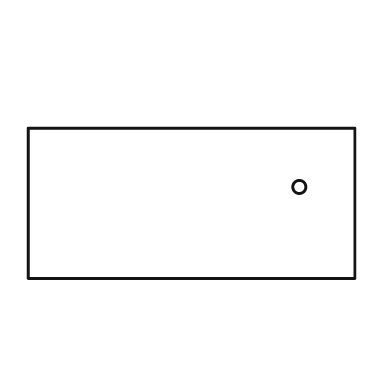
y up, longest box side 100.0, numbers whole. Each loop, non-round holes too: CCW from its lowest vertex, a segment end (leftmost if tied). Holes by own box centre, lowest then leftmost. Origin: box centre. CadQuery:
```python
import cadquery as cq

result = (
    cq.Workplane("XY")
    .moveTo(-50.0, -23.0)
    .lineTo(50.0, -23.0)
    .lineTo(50.0, 23.0)
    .lineTo(-50.0, 23.0)
    .close()
    .moveTo(33.0, 5.0)
    .circle(2.0)
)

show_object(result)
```